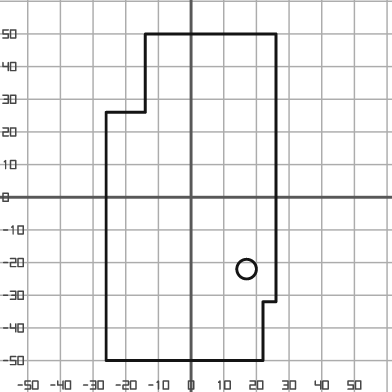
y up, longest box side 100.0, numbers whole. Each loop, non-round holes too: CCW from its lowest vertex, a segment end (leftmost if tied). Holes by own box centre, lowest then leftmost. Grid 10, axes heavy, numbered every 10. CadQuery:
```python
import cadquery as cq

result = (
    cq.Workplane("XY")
    .moveTo(-26.0, -50.0)
    .lineTo(22.0, -50.0)
    .lineTo(22.0, -32.0)
    .lineTo(26.0, -32.0)
    .lineTo(26.0, 50.0)
    .lineTo(-14.0, 50.0)
    .lineTo(-14.0, 26.0)
    .lineTo(-26.0, 26.0)
    .close()
    .moveTo(17.0, -22.0)
    .circle(3.0)
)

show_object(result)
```